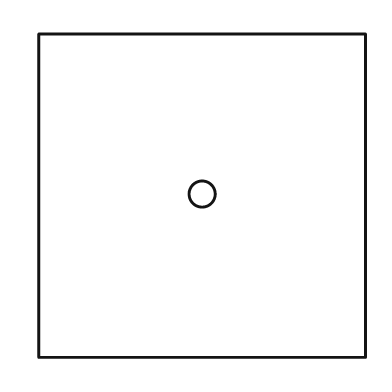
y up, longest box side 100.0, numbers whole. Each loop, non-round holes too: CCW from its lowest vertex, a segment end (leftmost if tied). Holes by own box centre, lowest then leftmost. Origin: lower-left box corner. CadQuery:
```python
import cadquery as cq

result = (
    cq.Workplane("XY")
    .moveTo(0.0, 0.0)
    .lineTo(100.0, 0.0)
    .lineTo(100.0, 99.0)
    .lineTo(0.0, 99.0)
    .close()
    .moveTo(50.0, 50.0)
    .circle(4.0)
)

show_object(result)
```